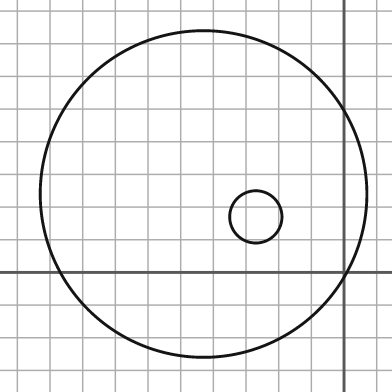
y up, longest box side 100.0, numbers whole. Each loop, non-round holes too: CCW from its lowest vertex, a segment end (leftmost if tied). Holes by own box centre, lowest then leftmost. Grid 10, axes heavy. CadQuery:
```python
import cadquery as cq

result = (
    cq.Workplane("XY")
    .moveTo(-43.0, 24.0)
    .circle(50.0)
    .moveTo(-27.0, 17.0)
    .circle(8.0)
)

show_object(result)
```